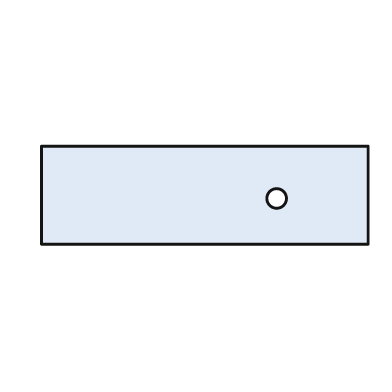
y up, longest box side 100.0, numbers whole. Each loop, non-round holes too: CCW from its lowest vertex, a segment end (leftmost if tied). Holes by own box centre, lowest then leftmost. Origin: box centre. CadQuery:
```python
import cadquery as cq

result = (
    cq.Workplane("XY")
    .moveTo(-50.0, -15.0)
    .lineTo(50.0, -15.0)
    .lineTo(50.0, 15.0)
    .lineTo(-50.0, 15.0)
    .close()
    .moveTo(22.0, -1.0)
    .circle(3.0)
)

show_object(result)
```